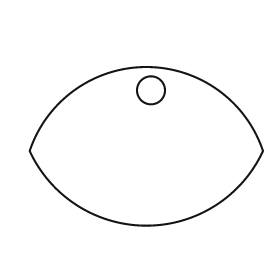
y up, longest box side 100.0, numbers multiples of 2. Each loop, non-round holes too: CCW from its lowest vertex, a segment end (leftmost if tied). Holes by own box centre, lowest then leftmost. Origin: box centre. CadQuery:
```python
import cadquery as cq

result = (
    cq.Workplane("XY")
    .moveTo(-50.0, -2.0)
    .threePointArc((0.0, -34.0), (50.0, -2.0))
    .threePointArc((0.0, 34.0), (-50.0, -2.0))
    .close()
    .moveTo(2.0, 24.0)
    .circle(6.0)
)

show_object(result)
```